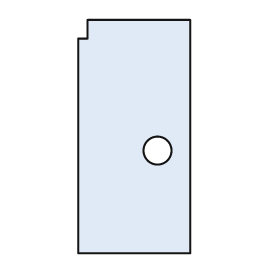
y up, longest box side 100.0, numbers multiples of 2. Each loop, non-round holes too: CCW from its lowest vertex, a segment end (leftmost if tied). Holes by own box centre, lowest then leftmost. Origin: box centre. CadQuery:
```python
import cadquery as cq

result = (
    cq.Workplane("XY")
    .moveTo(-24.0, -50.0)
    .lineTo(24.0, -50.0)
    .lineTo(24.0, 50.0)
    .lineTo(-20.0, 50.0)
    .lineTo(-20.0, 42.0)
    .lineTo(-24.0, 42.0)
    .close()
    .moveTo(10.0, -6.0)
    .circle(6.0)
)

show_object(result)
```